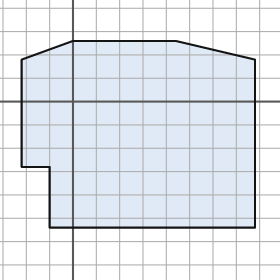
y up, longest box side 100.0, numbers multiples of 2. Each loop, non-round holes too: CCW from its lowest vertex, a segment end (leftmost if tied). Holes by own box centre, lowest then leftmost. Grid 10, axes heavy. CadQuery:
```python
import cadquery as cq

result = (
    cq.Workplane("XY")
    .moveTo(-10.0, -54.0)
    .lineTo(78.0, -54.0)
    .lineTo(78.0, 18.0)
    .lineTo(44.0, 26.0)
    .lineTo(0.0, 26.0)
    .lineTo(-22.0, 18.0)
    .lineTo(-22.0, -28.0)
    .lineTo(-10.0, -28.0)
    .close()
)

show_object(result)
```